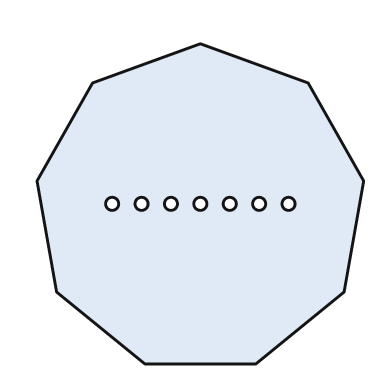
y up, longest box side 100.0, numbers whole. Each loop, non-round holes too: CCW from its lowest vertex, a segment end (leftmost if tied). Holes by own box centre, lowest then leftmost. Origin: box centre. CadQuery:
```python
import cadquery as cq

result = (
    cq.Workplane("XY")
    .moveTo(-17.0, -49.0)
    .lineTo(17.0, -49.0)
    .lineTo(44.0, -27.0)
    .lineTo(50.0, 7.0)
    .lineTo(33.0, 37.0)
    .lineTo(0.0, 49.0)
    .lineTo(-33.0, 37.0)
    .lineTo(-50.0, 7.0)
    .lineTo(-44.0, -27.0)
    .close()
    .moveTo(-27.0, 0.0)
    .circle(2.0)
    .moveTo(-18.0, 0.0)
    .circle(2.0)
    .moveTo(-9.0, 0.0)
    .circle(2.0)
    .moveTo(0.0, 0.0)
    .circle(2.0)
    .moveTo(9.0, 0.0)
    .circle(2.0)
    .moveTo(18.0, 0.0)
    .circle(2.0)
    .moveTo(27.0, 0.0)
    .circle(2.0)
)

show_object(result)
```